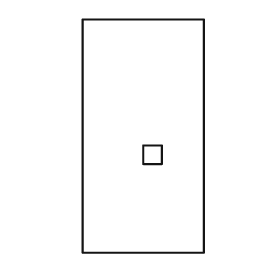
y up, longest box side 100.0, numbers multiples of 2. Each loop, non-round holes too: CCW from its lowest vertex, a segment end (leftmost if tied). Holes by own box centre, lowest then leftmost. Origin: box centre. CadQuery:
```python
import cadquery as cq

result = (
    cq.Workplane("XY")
    .moveTo(-26.0, -50.0)
    .lineTo(26.0, -50.0)
    .lineTo(26.0, 50.0)
    .lineTo(-26.0, 50.0)
    .close()
    .moveTo(0.0, -12.0)
    .lineTo(8.0, -12.0)
    .lineTo(8.0, -4.0)
    .lineTo(0.0, -4.0)
    .close()
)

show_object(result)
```